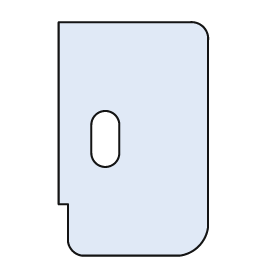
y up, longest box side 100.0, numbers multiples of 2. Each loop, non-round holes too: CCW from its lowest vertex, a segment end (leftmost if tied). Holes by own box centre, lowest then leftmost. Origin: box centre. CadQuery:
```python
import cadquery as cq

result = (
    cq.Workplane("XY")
    .moveTo(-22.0, -50.0)
    .lineTo(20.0, -50.0)
    .threePointArc((28.0, -46.0), (32.0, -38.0))
    .lineTo(32.0, 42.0)
    .threePointArc((30.0, 48.0), (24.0, 50.0))
    .lineTo(-32.0, 50.0)
    .lineTo(-32.0, -28.0)
    .lineTo(-28.0, -28.0)
    .lineTo(-28.0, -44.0)
    .threePointArc((-26.0, -48.0), (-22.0, -50.0))
    .close()
    .moveTo(-18.0, -6.0)
    .threePointArc((-12.0, -12.0), (-6.0, -6.0))
    .lineTo(-6.0, 6.0)
    .threePointArc((-12.0, 12.0), (-18.0, 6.0))
    .close()
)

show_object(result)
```